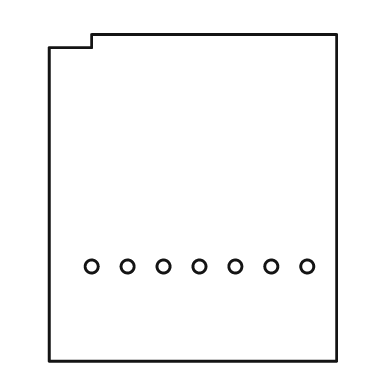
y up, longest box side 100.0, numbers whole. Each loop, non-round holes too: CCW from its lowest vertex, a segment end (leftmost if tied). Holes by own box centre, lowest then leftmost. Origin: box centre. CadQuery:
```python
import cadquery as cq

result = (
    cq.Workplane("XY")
    .moveTo(-44.0, -50.0)
    .lineTo(44.0, -50.0)
    .lineTo(44.0, 50.0)
    .lineTo(-31.0, 50.0)
    .lineTo(-31.0, 46.0)
    .lineTo(-44.0, 46.0)
    .close()
    .moveTo(-31.0, -21.0)
    .circle(2.0)
    .moveTo(-20.0, -21.0)
    .circle(2.0)
    .moveTo(-9.0, -21.0)
    .circle(2.0)
    .moveTo(2.0, -21.0)
    .circle(2.0)
    .moveTo(13.0, -21.0)
    .circle(2.0)
    .moveTo(24.0, -21.0)
    .circle(2.0)
    .moveTo(35.0, -21.0)
    .circle(2.0)
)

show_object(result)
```